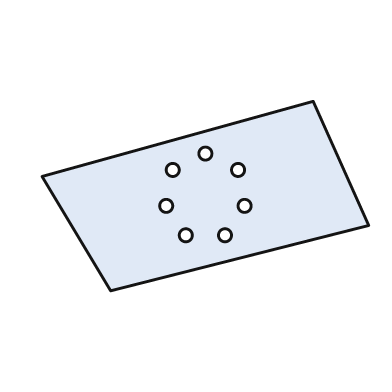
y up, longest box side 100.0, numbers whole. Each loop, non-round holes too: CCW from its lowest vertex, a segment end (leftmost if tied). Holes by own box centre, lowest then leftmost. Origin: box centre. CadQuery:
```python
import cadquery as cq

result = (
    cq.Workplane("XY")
    .moveTo(-29.0, -29.0)
    .lineTo(50.0, -9.0)
    .lineTo(33.0, 29.0)
    .lineTo(-50.0, 6.0)
    .close()
    .moveTo(-6.0, -12.0)
    .circle(2.0)
    .moveTo(6.0, -12.0)
    .circle(2.0)
    .moveTo(-12.0, -3.0)
    .circle(2.0)
    .moveTo(12.0, -3.0)
    .circle(2.0)
    .moveTo(-10.0, 8.0)
    .circle(2.0)
    .moveTo(10.0, 8.0)
    .circle(2.0)
    .moveTo(0.0, 13.0)
    .circle(2.0)
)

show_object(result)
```